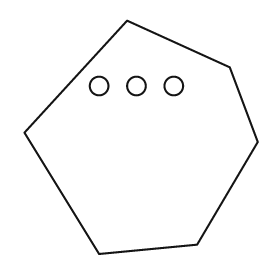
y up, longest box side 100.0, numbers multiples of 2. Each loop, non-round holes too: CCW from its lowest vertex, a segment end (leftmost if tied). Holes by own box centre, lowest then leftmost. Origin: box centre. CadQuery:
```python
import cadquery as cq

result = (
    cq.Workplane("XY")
    .moveTo(-18.0, -50.0)
    .lineTo(24.0, -46.0)
    .lineTo(50.0, -2.0)
    .lineTo(38.0, 30.0)
    .lineTo(-6.0, 50.0)
    .lineTo(-50.0, 2.0)
    .close()
    .moveTo(-18.0, 22.0)
    .circle(4.0)
    .moveTo(-2.0, 22.0)
    .circle(4.0)
    .moveTo(14.0, 22.0)
    .circle(4.0)
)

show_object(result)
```